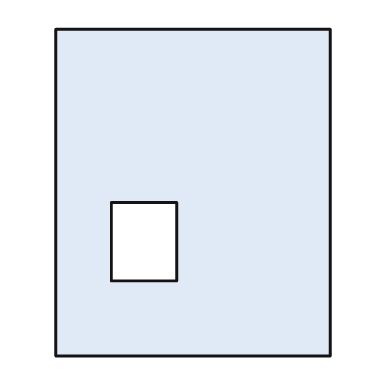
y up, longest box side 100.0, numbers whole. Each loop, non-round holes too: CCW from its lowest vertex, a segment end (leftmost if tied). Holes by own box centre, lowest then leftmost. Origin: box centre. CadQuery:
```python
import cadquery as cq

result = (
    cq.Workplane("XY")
    .moveTo(-42.0, -50.0)
    .lineTo(42.0, -50.0)
    .lineTo(42.0, 50.0)
    .lineTo(-42.0, 50.0)
    .close()
    .moveTo(-25.0, -27.0)
    .lineTo(-5.0, -27.0)
    .lineTo(-5.0, -3.0)
    .lineTo(-25.0, -3.0)
    .close()
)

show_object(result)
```